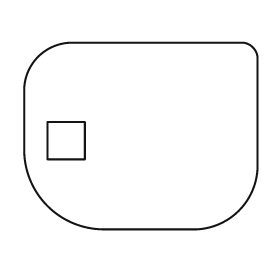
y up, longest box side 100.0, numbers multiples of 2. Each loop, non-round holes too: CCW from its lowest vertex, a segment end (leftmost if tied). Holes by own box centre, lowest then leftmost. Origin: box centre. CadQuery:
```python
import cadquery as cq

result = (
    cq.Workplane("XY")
    .moveTo(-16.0, -40.0)
    .lineTo(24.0, -40.0)
    .threePointArc((42.0, -32.0), (50.0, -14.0))
    .lineTo(50.0, 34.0)
    .threePointArc((48.0, 38.0), (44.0, 40.0))
    .lineTo(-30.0, 40.0)
    .threePointArc((-44.0, 34.0), (-50.0, 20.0))
    .lineTo(-50.0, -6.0)
    .threePointArc((-40.0, -30.0), (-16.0, -40.0))
    .close()
    .moveTo(-40.0, -10.0)
    .lineTo(-24.0, -10.0)
    .lineTo(-24.0, 6.0)
    .lineTo(-40.0, 6.0)
    .close()
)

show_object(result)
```